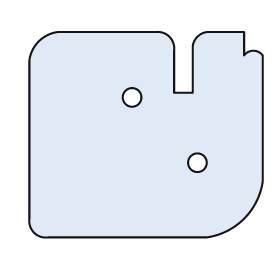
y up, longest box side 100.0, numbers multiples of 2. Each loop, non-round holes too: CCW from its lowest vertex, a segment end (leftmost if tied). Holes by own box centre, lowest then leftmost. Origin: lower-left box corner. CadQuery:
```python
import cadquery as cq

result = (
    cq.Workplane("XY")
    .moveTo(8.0, 0.0)
    .lineTo(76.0, 0.0)
    .threePointArc((92.0, 8.0), (100.0, 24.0))
    .lineTo(100.0, 78.0)
    .threePointArc((96.0, 80.0), (92.0, 78.0))
    .lineTo(92.0, 88.0)
    .lineTo(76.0, 88.0)
    .threePointArc((72.0, 86.0), (70.0, 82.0))
    .lineTo(70.0, 62.0)
    .lineTo(62.0, 62.0)
    .lineTo(62.0, 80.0)
    .threePointArc((60.0, 86.0), (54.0, 88.0))
    .lineTo(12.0, 88.0)
    .threePointArc((4.0, 84.0), (0.0, 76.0))
    .lineTo(0.0, 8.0)
    .threePointArc((2.0, 2.0), (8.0, 0.0))
    .close()
    .moveTo(72.0, 32.0)
    .circle(4.0)
    .moveTo(44.0, 60.0)
    .circle(4.0)
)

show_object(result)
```